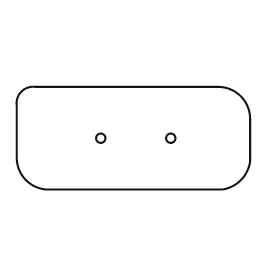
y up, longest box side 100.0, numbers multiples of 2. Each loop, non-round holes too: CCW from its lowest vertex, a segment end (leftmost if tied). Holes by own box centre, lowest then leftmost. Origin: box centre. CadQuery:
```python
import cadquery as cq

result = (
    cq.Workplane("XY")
    .moveTo(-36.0, -22.0)
    .lineTo(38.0, -22.0)
    .threePointArc((46.0, -18.0), (50.0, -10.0))
    .lineTo(50.0, 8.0)
    .threePointArc((46.0, 18.0), (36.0, 22.0))
    .lineTo(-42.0, 22.0)
    .threePointArc((-48.0, 20.0), (-50.0, 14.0))
    .lineTo(-50.0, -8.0)
    .threePointArc((-46.0, -18.0), (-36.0, -22.0))
    .close()
    .moveTo(-14.0, 0.0)
    .circle(2.0)
    .moveTo(16.0, 0.0)
    .circle(2.0)
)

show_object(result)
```